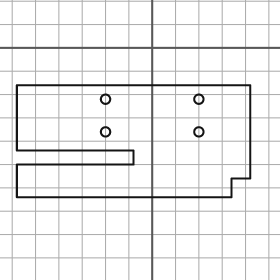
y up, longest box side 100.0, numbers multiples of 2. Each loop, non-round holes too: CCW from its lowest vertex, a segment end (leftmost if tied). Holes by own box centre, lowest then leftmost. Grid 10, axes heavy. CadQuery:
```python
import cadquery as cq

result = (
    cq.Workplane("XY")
    .moveTo(-58.0, -64.0)
    .lineTo(34.0, -64.0)
    .lineTo(34.0, -56.0)
    .lineTo(42.0, -56.0)
    .lineTo(42.0, -16.0)
    .lineTo(-58.0, -16.0)
    .lineTo(-58.0, -44.0)
    .lineTo(-8.0, -44.0)
    .lineTo(-8.0, -50.0)
    .lineTo(-58.0, -50.0)
    .close()
    .moveTo(-20.0, -36.0)
    .circle(2.0)
    .moveTo(20.0, -36.0)
    .circle(2.0)
    .moveTo(-20.0, -22.0)
    .circle(2.0)
    .moveTo(20.0, -22.0)
    .circle(2.0)
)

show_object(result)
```